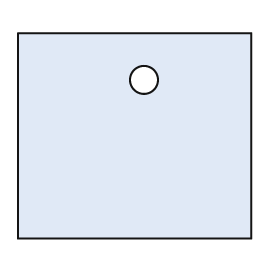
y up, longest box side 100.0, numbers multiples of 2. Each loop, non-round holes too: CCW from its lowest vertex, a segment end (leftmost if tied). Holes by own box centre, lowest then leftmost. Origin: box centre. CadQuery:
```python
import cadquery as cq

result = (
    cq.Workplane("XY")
    .moveTo(-50.0, -44.0)
    .lineTo(50.0, -44.0)
    .lineTo(50.0, 44.0)
    .lineTo(-50.0, 44.0)
    .close()
    .moveTo(4.0, 24.0)
    .circle(6.0)
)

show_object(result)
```